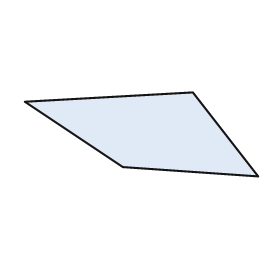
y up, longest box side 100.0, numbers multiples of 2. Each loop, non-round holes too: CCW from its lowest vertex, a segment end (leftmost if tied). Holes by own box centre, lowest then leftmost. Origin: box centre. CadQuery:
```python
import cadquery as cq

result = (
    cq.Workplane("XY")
    .moveTo(50.0, -18.0)
    .lineTo(22.0, 18.0)
    .lineTo(-50.0, 14.0)
    .lineTo(-8.0, -14.0)
    .close()
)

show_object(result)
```